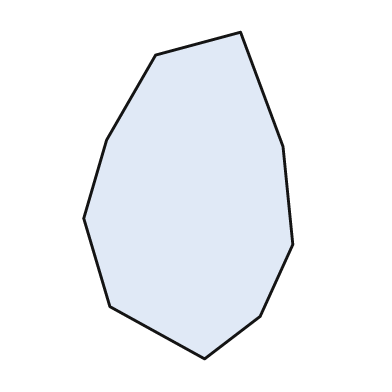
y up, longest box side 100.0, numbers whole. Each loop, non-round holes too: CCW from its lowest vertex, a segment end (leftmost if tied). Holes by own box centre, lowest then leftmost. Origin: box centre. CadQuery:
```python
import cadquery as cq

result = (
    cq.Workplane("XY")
    .moveTo(5.0, -50.0)
    .lineTo(22.0, -37.0)
    .lineTo(32.0, -15.0)
    .lineTo(29.0, 15.0)
    .lineTo(16.0, 50.0)
    .lineTo(-10.0, 43.0)
    .lineTo(-25.0, 17.0)
    .lineTo(-32.0, -7.0)
    .lineTo(-24.0, -34.0)
    .close()
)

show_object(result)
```